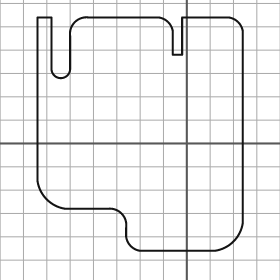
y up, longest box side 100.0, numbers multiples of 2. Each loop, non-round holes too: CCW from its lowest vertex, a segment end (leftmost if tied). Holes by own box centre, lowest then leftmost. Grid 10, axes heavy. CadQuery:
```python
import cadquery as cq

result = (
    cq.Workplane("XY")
    .moveTo(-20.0, -46.0)
    .lineTo(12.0, -46.0)
    .threePointArc((20.0, -42.0), (24.0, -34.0))
    .lineTo(24.0, 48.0)
    .threePointArc((22.0, 52.0), (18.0, 54.0))
    .lineTo(-2.0, 54.0)
    .lineTo(-2.0, 38.0)
    .lineTo(-6.0, 38.0)
    .lineTo(-6.0, 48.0)
    .threePointArc((-8.0, 52.0), (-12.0, 54.0))
    .lineTo(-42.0, 54.0)
    .threePointArc((-48.0, 52.0), (-50.0, 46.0))
    .lineTo(-50.0, 32.0)
    .threePointArc((-54.0, 28.0), (-58.0, 32.0))
    .lineTo(-58.0, 54.0)
    .lineTo(-64.0, 54.0)
    .lineTo(-64.0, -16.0)
    .threePointArc((-60.0, -24.0), (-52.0, -28.0))
    .lineTo(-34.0, -28.0)
    .threePointArc((-28.0, -30.0), (-26.0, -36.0))
    .lineTo(-26.0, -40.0)
    .threePointArc((-24.0, -44.0), (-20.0, -46.0))
    .close()
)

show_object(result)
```